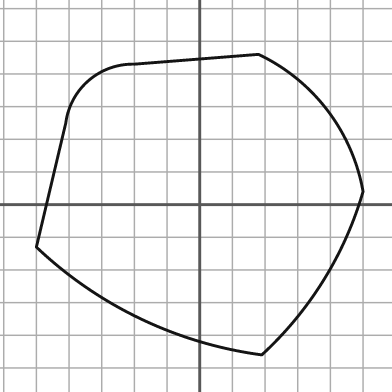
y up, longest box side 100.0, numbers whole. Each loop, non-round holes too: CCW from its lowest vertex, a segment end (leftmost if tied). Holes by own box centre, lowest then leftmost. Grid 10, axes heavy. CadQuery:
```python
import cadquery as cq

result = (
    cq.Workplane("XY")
    .moveTo(19.0, -46.0)
    .threePointArc((38.0, -23.0), (50.0, 4.0))
    .threePointArc((39.0, 29.0), (18.0, 46.0))
    .lineTo(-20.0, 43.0)
    .threePointArc((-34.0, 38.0), (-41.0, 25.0))
    .lineTo(-50.0, -13.0)
    .threePointArc((-18.0, -35.0), (19.0, -46.0))
    .close()
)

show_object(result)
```